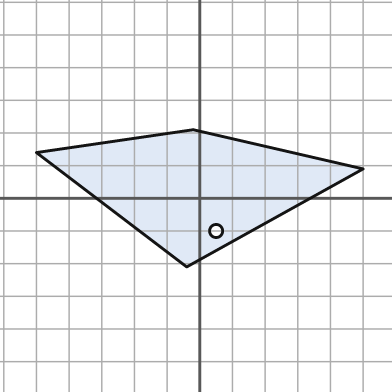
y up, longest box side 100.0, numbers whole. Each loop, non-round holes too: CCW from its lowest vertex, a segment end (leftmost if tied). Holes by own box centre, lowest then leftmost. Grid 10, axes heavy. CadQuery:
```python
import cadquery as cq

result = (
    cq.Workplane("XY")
    .moveTo(-4.0, -21.0)
    .lineTo(50.0, 9.0)
    .lineTo(-2.0, 21.0)
    .lineTo(-50.0, 14.0)
    .close()
    .moveTo(5.0, -10.0)
    .circle(2.0)
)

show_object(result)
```